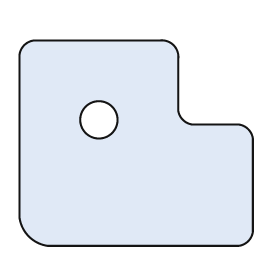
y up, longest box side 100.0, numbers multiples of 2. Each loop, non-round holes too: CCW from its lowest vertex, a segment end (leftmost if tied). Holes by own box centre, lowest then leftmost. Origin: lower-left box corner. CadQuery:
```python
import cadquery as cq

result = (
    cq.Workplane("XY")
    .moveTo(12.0, 0.0)
    .lineTo(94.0, 0.0)
    .threePointArc((98.0, 2.0), (100.0, 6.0))
    .lineTo(100.0, 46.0)
    .threePointArc((98.0, 50.0), (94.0, 52.0))
    .lineTo(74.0, 52.0)
    .threePointArc((70.0, 54.0), (68.0, 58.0))
    .lineTo(68.0, 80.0)
    .threePointArc((66.0, 86.0), (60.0, 88.0))
    .lineTo(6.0, 88.0)
    .threePointArc((2.0, 86.0), (0.0, 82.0))
    .lineTo(0.0, 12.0)
    .threePointArc((4.0, 4.0), (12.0, 0.0))
    .close()
    .moveTo(34.0, 54.0)
    .circle(8.0)
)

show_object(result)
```